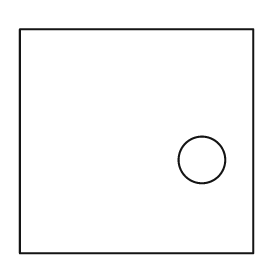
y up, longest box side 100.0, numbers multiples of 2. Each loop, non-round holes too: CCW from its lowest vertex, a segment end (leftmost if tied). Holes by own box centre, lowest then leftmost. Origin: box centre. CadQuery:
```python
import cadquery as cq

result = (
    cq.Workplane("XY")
    .moveTo(-50.0, -48.0)
    .lineTo(50.0, -48.0)
    .lineTo(50.0, 48.0)
    .lineTo(-50.0, 48.0)
    .close()
    .moveTo(28.0, -8.0)
    .circle(10.0)
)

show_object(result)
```